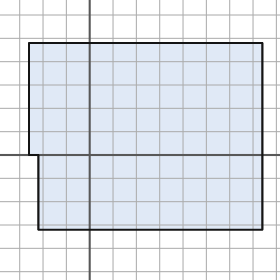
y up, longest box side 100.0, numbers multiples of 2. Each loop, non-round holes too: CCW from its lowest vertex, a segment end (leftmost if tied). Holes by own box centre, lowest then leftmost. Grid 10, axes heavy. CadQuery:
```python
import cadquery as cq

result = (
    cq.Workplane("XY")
    .moveTo(-22.0, -32.0)
    .lineTo(74.0, -32.0)
    .lineTo(74.0, 48.0)
    .lineTo(-26.0, 48.0)
    .lineTo(-26.0, 0.0)
    .lineTo(-22.0, 0.0)
    .close()
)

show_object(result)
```